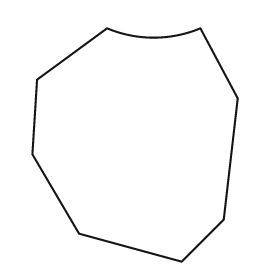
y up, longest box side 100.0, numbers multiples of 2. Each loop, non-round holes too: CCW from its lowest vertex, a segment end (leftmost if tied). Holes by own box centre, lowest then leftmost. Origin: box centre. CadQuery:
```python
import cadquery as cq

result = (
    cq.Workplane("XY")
    .moveTo(20.0, -50.0)
    .lineTo(38.0, -32.0)
    .lineTo(44.0, 20.0)
    .lineTo(28.0, 50.0)
    .threePointArc((8.0, 46.0), (-12.0, 50.0))
    .lineTo(-42.0, 28.0)
    .lineTo(-44.0, -4.0)
    .lineTo(-24.0, -38.0)
    .close()
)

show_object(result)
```